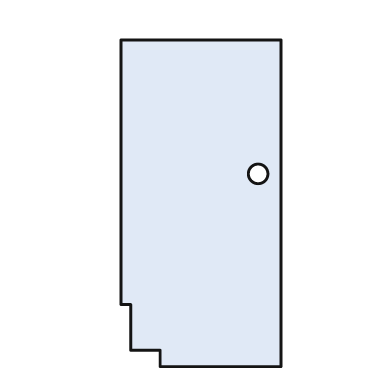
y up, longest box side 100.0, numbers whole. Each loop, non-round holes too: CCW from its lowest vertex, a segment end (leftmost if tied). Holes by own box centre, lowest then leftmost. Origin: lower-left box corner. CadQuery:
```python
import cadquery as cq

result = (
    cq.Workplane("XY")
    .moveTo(12.0, 0.0)
    .lineTo(49.0, 0.0)
    .lineTo(49.0, 100.0)
    .lineTo(0.0, 100.0)
    .lineTo(0.0, 19.0)
    .lineTo(3.0, 19.0)
    .lineTo(3.0, 5.0)
    .lineTo(12.0, 5.0)
    .close()
    .moveTo(42.0, 59.0)
    .circle(3.0)
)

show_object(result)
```